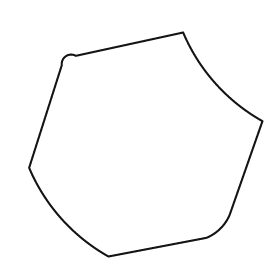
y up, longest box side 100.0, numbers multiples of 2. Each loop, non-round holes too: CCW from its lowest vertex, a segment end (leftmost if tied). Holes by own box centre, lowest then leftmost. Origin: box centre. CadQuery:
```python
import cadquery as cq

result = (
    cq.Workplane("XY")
    .moveTo(-16.0, -48.0)
    .lineTo(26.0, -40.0)
    .threePointArc((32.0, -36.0), (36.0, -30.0))
    .lineTo(50.0, 10.0)
    .threePointArc((30.0, 26.0), (16.0, 48.0))
    .lineTo(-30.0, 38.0)
    .threePointArc((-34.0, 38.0), (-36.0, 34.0))
    .lineTo(-50.0, -10.0)
    .threePointArc((-36.0, -32.0), (-16.0, -48.0))
    .close()
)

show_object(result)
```